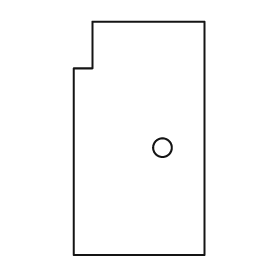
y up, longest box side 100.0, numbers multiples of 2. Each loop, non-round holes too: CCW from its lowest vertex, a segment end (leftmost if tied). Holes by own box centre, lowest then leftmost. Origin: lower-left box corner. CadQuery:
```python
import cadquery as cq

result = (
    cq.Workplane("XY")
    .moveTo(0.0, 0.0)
    .lineTo(56.0, 0.0)
    .lineTo(56.0, 100.0)
    .lineTo(8.0, 100.0)
    .lineTo(8.0, 80.0)
    .lineTo(0.0, 80.0)
    .close()
    .moveTo(38.0, 46.0)
    .circle(4.0)
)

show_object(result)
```